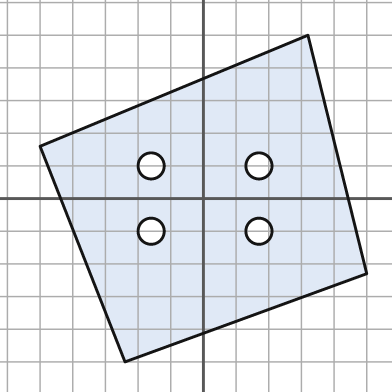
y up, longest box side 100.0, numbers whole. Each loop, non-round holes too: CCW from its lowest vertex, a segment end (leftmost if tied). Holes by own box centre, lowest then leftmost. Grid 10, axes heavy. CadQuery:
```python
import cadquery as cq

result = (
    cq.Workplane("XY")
    .moveTo(-24.0, -50.0)
    .lineTo(50.0, -23.0)
    .lineTo(32.0, 50.0)
    .lineTo(-50.0, 16.0)
    .close()
    .moveTo(-16.0, -10.0)
    .circle(4.0)
    .moveTo(17.0, -10.0)
    .circle(4.0)
    .moveTo(-16.0, 10.0)
    .circle(4.0)
    .moveTo(17.0, 10.0)
    .circle(4.0)
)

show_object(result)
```